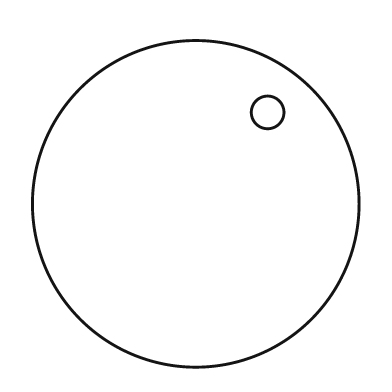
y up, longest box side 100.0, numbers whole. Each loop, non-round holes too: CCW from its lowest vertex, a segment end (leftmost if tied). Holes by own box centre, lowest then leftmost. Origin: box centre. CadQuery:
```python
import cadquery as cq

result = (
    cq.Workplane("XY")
    .moveTo(0.0, 0.0)
    .circle(50.0)
    .moveTo(22.0, 28.0)
    .circle(5.0)
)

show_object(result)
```